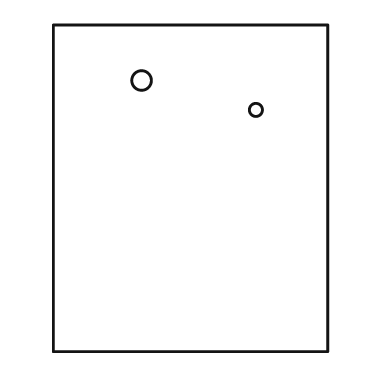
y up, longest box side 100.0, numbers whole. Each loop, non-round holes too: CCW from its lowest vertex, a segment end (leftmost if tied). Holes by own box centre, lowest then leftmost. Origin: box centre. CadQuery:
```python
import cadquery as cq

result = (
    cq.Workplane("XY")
    .moveTo(-42.0, -50.0)
    .lineTo(42.0, -50.0)
    .lineTo(42.0, 50.0)
    .lineTo(-42.0, 50.0)
    .close()
    .moveTo(20.0, 24.0)
    .circle(2.0)
    .moveTo(-15.0, 33.0)
    .circle(3.0)
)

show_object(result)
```